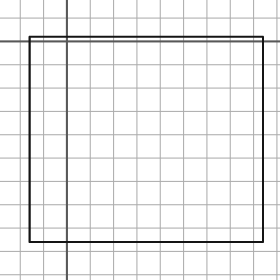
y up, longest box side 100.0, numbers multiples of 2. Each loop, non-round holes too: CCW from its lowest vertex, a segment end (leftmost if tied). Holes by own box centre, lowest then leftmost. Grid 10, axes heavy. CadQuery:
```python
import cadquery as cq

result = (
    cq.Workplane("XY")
    .moveTo(-16.0, -86.0)
    .lineTo(84.0, -86.0)
    .lineTo(84.0, 2.0)
    .lineTo(-16.0, 2.0)
    .close()
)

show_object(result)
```